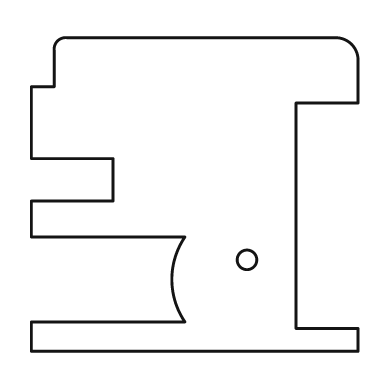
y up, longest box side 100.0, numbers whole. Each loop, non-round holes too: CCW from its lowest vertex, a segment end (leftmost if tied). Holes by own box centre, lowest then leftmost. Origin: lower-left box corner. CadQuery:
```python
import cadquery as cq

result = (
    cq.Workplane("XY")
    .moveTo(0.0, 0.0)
    .lineTo(100.0, 0.0)
    .lineTo(100.0, 7.0)
    .lineTo(81.0, 7.0)
    .lineTo(81.0, 76.0)
    .lineTo(100.0, 76.0)
    .lineTo(100.0, 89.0)
    .threePointArc((98.0, 94.0), (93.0, 96.0))
    .lineTo(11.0, 96.0)
    .threePointArc((8.0, 95.0), (7.0, 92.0))
    .lineTo(7.0, 81.0)
    .lineTo(0.0, 81.0)
    .lineTo(0.0, 59.0)
    .lineTo(25.0, 59.0)
    .lineTo(25.0, 46.0)
    .lineTo(0.0, 46.0)
    .lineTo(0.0, 35.0)
    .lineTo(47.0, 35.0)
    .threePointArc((43.0, 22.0), (47.0, 9.0))
    .lineTo(0.0, 9.0)
    .close()
    .moveTo(66.0, 28.0)
    .circle(3.0)
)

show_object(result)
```